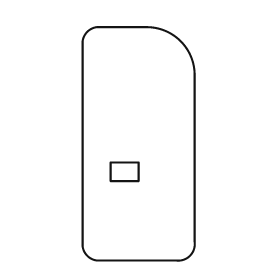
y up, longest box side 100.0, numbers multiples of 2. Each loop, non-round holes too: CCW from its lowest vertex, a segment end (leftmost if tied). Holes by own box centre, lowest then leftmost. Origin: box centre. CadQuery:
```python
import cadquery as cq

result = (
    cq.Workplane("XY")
    .moveTo(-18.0, -50.0)
    .lineTo(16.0, -50.0)
    .threePointArc((22.0, -48.0), (24.0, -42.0))
    .lineTo(24.0, 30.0)
    .threePointArc((18.0, 44.0), (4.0, 50.0))
    .lineTo(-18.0, 50.0)
    .threePointArc((-22.0, 48.0), (-24.0, 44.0))
    .lineTo(-24.0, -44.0)
    .threePointArc((-22.0, -48.0), (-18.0, -50.0))
    .close()
    .moveTo(-12.0, -16.0)
    .lineTo(0.0, -16.0)
    .lineTo(0.0, -8.0)
    .lineTo(-12.0, -8.0)
    .close()
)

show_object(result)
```